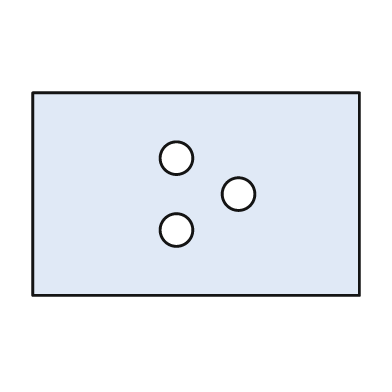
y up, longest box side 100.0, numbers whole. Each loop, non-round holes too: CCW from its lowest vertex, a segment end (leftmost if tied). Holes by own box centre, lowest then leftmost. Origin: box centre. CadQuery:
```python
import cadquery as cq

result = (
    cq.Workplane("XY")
    .moveTo(-50.0, -31.0)
    .lineTo(50.0, -31.0)
    .lineTo(50.0, 31.0)
    .lineTo(-50.0, 31.0)
    .close()
    .moveTo(-6.0, -11.0)
    .circle(5.0)
    .moveTo(13.0, 0.0)
    .circle(5.0)
    .moveTo(-6.0, 11.0)
    .circle(5.0)
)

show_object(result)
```